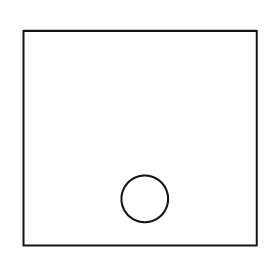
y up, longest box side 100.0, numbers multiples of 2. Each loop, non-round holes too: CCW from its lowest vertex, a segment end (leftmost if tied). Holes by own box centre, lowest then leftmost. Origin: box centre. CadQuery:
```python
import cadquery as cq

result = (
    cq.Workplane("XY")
    .moveTo(-50.0, -46.0)
    .lineTo(50.0, -46.0)
    .lineTo(50.0, 46.0)
    .lineTo(-50.0, 46.0)
    .close()
    .moveTo(2.0, -26.0)
    .circle(10.0)
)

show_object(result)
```